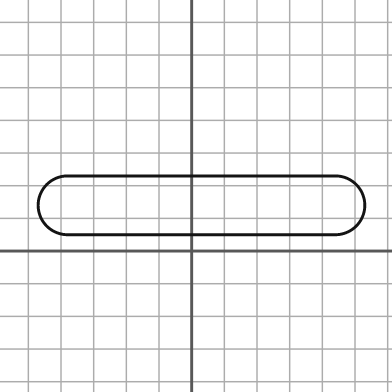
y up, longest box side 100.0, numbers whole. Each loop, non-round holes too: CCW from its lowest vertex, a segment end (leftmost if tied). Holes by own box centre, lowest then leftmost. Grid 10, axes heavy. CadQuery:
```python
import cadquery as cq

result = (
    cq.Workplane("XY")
    .moveTo(-38.0, 5.0)
    .lineTo(44.0, 5.0)
    .threePointArc((53.0, 14.0), (44.0, 23.0))
    .lineTo(-38.0, 23.0)
    .threePointArc((-47.0, 14.0), (-38.0, 5.0))
    .close()
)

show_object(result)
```